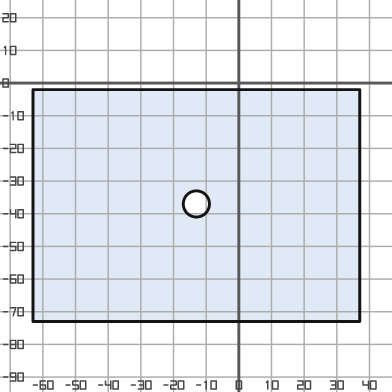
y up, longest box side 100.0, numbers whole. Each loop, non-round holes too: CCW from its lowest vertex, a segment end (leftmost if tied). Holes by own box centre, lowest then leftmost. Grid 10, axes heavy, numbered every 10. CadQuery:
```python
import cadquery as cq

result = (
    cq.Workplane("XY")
    .moveTo(-63.0, -73.0)
    .lineTo(37.0, -73.0)
    .lineTo(37.0, -2.0)
    .lineTo(-63.0, -2.0)
    .close()
    .moveTo(-13.0, -37.0)
    .circle(4.0)
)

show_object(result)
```